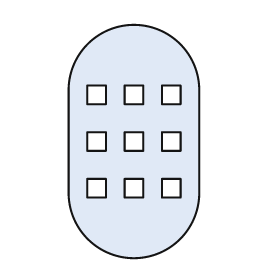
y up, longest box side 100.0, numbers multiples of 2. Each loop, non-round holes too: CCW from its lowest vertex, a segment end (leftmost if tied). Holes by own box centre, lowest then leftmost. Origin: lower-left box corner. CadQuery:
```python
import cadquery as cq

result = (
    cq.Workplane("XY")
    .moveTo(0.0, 28.0)
    .threePointArc((28.0, 0.0), (56.0, 28.0))
    .lineTo(56.0, 72.0)
    .threePointArc((28.0, 100.0), (0.0, 72.0))
    .close()
    .moveTo(8.0, 26.0)
    .lineTo(16.0, 26.0)
    .lineTo(16.0, 34.0)
    .lineTo(8.0, 34.0)
    .close()
    .moveTo(24.0, 26.0)
    .lineTo(32.0, 26.0)
    .lineTo(32.0, 34.0)
    .lineTo(24.0, 34.0)
    .close()
    .moveTo(40.0, 26.0)
    .lineTo(48.0, 26.0)
    .lineTo(48.0, 34.0)
    .lineTo(40.0, 34.0)
    .close()
    .moveTo(8.0, 46.0)
    .lineTo(16.0, 46.0)
    .lineTo(16.0, 54.0)
    .lineTo(8.0, 54.0)
    .close()
    .moveTo(24.0, 46.0)
    .lineTo(32.0, 46.0)
    .lineTo(32.0, 54.0)
    .lineTo(24.0, 54.0)
    .close()
    .moveTo(40.0, 46.0)
    .lineTo(48.0, 46.0)
    .lineTo(48.0, 54.0)
    .lineTo(40.0, 54.0)
    .close()
    .moveTo(8.0, 66.0)
    .lineTo(16.0, 66.0)
    .lineTo(16.0, 74.0)
    .lineTo(8.0, 74.0)
    .close()
    .moveTo(24.0, 66.0)
    .lineTo(32.0, 66.0)
    .lineTo(32.0, 74.0)
    .lineTo(24.0, 74.0)
    .close()
    .moveTo(40.0, 66.0)
    .lineTo(48.0, 66.0)
    .lineTo(48.0, 74.0)
    .lineTo(40.0, 74.0)
    .close()
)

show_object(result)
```